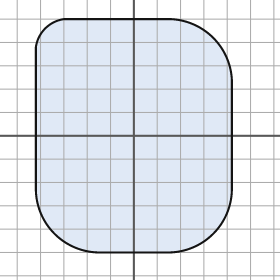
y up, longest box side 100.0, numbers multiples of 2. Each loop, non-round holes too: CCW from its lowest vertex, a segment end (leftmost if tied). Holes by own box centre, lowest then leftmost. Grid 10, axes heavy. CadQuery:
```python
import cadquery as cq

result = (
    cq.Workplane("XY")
    .moveTo(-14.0, -50.0)
    .lineTo(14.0, -50.0)
    .threePointArc((34.0, -42.0), (42.0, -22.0))
    .lineTo(42.0, 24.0)
    .threePointArc((34.0, 42.0), (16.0, 50.0))
    .lineTo(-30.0, 50.0)
    .threePointArc((-38.0, 46.0), (-42.0, 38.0))
    .lineTo(-42.0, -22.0)
    .threePointArc((-34.0, -42.0), (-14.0, -50.0))
    .close()
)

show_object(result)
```